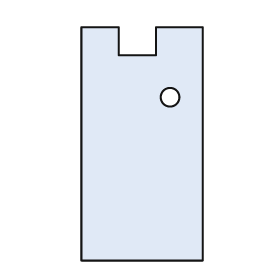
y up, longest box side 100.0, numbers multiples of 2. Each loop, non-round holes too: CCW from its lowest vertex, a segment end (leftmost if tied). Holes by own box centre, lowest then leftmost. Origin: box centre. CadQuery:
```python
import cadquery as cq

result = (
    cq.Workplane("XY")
    .moveTo(-26.0, -50.0)
    .lineTo(26.0, -50.0)
    .lineTo(26.0, 50.0)
    .lineTo(6.0, 50.0)
    .lineTo(6.0, 38.0)
    .lineTo(-10.0, 38.0)
    .lineTo(-10.0, 50.0)
    .lineTo(-26.0, 50.0)
    .close()
    .moveTo(12.0, 20.0)
    .circle(4.0)
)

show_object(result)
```